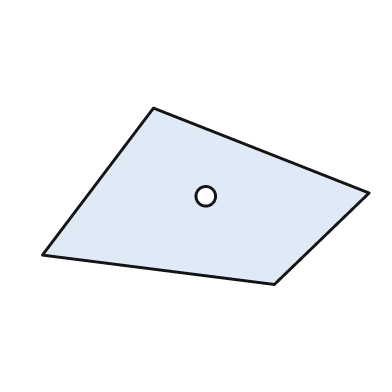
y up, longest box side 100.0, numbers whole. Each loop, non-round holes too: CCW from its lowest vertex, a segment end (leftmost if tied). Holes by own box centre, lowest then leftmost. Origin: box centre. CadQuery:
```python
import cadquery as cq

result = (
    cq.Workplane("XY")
    .moveTo(21.0, -27.0)
    .lineTo(50.0, 1.0)
    .lineTo(-16.0, 27.0)
    .lineTo(-50.0, -18.0)
    .close()
    .moveTo(0.0, 0.0)
    .circle(3.0)
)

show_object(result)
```